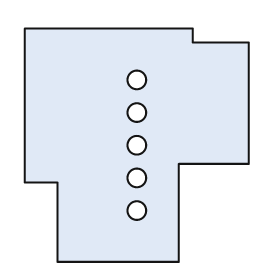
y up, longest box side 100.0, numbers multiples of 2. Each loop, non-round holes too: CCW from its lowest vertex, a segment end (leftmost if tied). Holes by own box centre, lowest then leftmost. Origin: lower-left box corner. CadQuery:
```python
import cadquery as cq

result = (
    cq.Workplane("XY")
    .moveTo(14.0, 0.0)
    .lineTo(66.0, 0.0)
    .lineTo(66.0, 42.0)
    .lineTo(96.0, 42.0)
    .lineTo(96.0, 94.0)
    .lineTo(72.0, 94.0)
    .lineTo(72.0, 100.0)
    .lineTo(0.0, 100.0)
    .lineTo(0.0, 34.0)
    .lineTo(14.0, 34.0)
    .close()
    .moveTo(48.0, 22.0)
    .circle(4.0)
    .moveTo(48.0, 36.0)
    .circle(4.0)
    .moveTo(48.0, 50.0)
    .circle(4.0)
    .moveTo(48.0, 64.0)
    .circle(4.0)
    .moveTo(48.0, 78.0)
    .circle(4.0)
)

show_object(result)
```